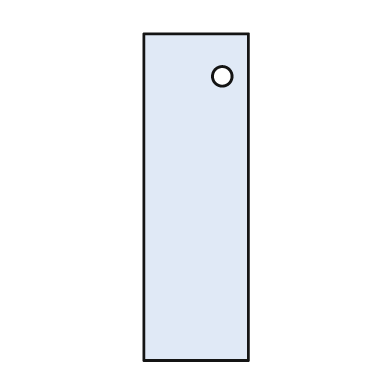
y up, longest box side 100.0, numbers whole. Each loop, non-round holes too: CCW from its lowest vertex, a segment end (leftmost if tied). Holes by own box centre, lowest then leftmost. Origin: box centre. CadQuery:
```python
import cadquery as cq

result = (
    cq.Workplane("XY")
    .moveTo(-16.0, -50.0)
    .lineTo(16.0, -50.0)
    .lineTo(16.0, 50.0)
    .lineTo(-16.0, 50.0)
    .close()
    .moveTo(8.0, 37.0)
    .circle(3.0)
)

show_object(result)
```